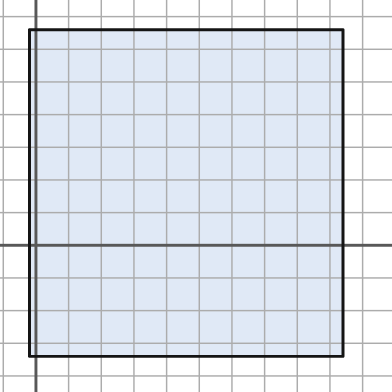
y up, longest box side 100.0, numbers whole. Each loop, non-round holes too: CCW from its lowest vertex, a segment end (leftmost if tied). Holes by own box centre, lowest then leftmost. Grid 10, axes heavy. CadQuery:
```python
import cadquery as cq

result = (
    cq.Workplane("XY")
    .moveTo(-2.0, -34.0)
    .lineTo(94.0, -34.0)
    .lineTo(94.0, 66.0)
    .lineTo(-2.0, 66.0)
    .close()
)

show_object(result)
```